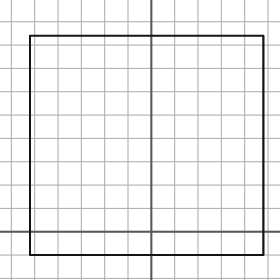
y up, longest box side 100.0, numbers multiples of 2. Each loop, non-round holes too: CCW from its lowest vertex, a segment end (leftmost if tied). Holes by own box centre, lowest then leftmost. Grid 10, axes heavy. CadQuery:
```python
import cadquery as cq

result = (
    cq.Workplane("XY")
    .moveTo(-52.0, -10.0)
    .lineTo(48.0, -10.0)
    .lineTo(48.0, 84.0)
    .lineTo(-52.0, 84.0)
    .close()
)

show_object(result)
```